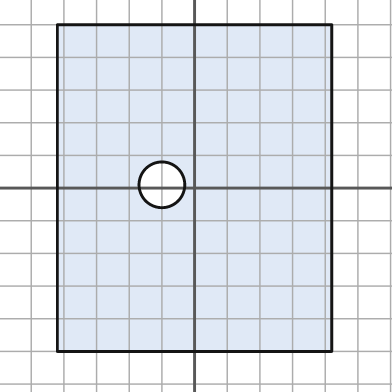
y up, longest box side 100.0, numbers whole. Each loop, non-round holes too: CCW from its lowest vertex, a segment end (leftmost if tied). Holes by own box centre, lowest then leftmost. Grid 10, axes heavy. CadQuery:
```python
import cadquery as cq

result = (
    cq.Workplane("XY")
    .moveTo(-42.0, -50.0)
    .lineTo(42.0, -50.0)
    .lineTo(42.0, 50.0)
    .lineTo(-42.0, 50.0)
    .close()
    .moveTo(-10.0, 1.0)
    .circle(7.0)
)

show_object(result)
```